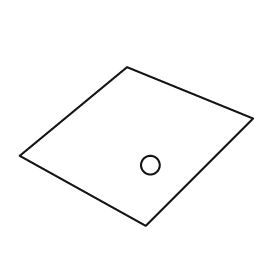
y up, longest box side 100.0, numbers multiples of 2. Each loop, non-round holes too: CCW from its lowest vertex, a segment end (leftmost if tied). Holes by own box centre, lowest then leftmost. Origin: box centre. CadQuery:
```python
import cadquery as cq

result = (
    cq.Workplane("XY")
    .moveTo(4.0, -34.0)
    .lineTo(50.0, 12.0)
    .lineTo(-4.0, 34.0)
    .lineTo(-50.0, -4.0)
    .close()
    .moveTo(6.0, -8.0)
    .circle(4.0)
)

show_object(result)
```